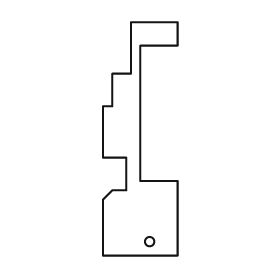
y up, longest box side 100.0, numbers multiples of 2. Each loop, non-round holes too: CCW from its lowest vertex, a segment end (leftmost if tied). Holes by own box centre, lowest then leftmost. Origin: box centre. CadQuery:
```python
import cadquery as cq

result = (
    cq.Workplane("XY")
    .moveTo(-16.0, -50.0)
    .lineTo(16.0, -50.0)
    .lineTo(16.0, -18.0)
    .lineTo(0.0, -18.0)
    .lineTo(0.0, 40.0)
    .lineTo(16.0, 40.0)
    .lineTo(16.0, 50.0)
    .lineTo(-4.0, 50.0)
    .lineTo(-4.0, 28.0)
    .lineTo(-12.0, 28.0)
    .lineTo(-12.0, 14.0)
    .lineTo(-16.0, 14.0)
    .lineTo(-16.0, -8.0)
    .lineTo(-6.0, -8.0)
    .lineTo(-6.0, -22.0)
    .lineTo(-12.0, -22.0)
    .lineTo(-16.0, -26.0)
    .close()
    .moveTo(4.0, -44.0)
    .circle(2.0)
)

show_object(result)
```